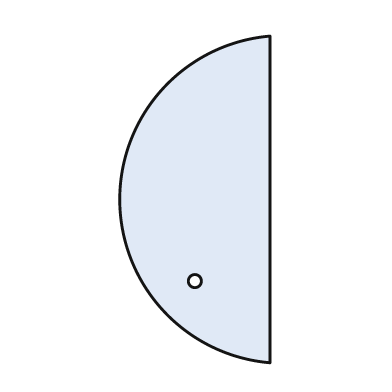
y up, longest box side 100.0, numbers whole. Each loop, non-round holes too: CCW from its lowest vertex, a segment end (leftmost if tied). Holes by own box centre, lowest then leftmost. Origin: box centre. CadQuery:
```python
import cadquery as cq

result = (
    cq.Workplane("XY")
    .moveTo(23.0, -50.0)
    .lineTo(23.0, 50.0)
    .threePointArc((-23.0, 0.0), (23.0, -50.0))
    .close()
    .moveTo(0.0, -25.0)
    .circle(2.0)
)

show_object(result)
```